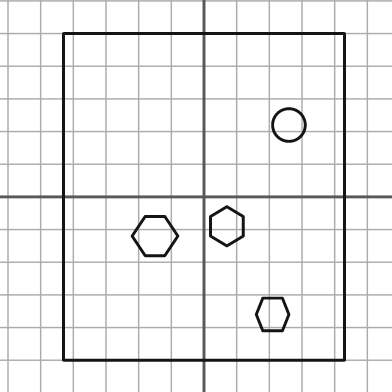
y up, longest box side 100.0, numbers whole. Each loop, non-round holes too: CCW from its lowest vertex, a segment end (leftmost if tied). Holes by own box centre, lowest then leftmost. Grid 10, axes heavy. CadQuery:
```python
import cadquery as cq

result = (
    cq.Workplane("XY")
    .moveTo(-43.0, -50.0)
    .lineTo(43.0, -50.0)
    .lineTo(43.0, 50.0)
    .lineTo(-43.0, 50.0)
    .close()
    .moveTo(18.0, -41.0)
    .lineTo(24.0, -41.0)
    .lineTo(26.0, -36.0)
    .lineTo(24.0, -31.0)
    .lineTo(18.0, -31.0)
    .lineTo(16.0, -36.0)
    .close()
    .moveTo(-18.0, -18.0)
    .lineTo(-12.0, -18.0)
    .lineTo(-8.0, -12.0)
    .lineTo(-12.0, -6.0)
    .lineTo(-18.0, -6.0)
    .lineTo(-22.0, -12.0)
    .close()
    .moveTo(7.0, -15.0)
    .lineTo(12.0, -12.0)
    .lineTo(12.0, -6.0)
    .lineTo(7.0, -3.0)
    .lineTo(2.0, -6.0)
    .lineTo(2.0, -12.0)
    .close()
    .moveTo(26.0, 22.0)
    .circle(5.0)
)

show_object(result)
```